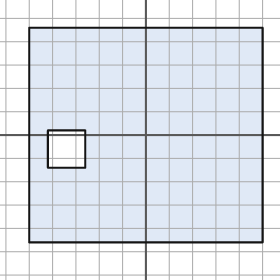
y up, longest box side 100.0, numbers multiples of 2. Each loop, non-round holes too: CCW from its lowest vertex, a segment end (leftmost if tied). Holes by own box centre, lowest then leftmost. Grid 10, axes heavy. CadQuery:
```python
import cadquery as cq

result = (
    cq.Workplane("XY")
    .moveTo(-50.0, -46.0)
    .lineTo(50.0, -46.0)
    .lineTo(50.0, 46.0)
    .lineTo(-50.0, 46.0)
    .close()
    .moveTo(-42.0, -14.0)
    .lineTo(-26.0, -14.0)
    .lineTo(-26.0, 2.0)
    .lineTo(-42.0, 2.0)
    .close()
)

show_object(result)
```